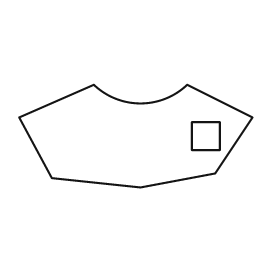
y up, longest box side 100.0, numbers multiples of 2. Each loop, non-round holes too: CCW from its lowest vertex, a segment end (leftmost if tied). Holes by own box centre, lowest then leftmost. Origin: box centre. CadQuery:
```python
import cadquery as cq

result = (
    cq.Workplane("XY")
    .moveTo(2.0, -22.0)
    .lineTo(34.0, -16.0)
    .lineTo(50.0, 8.0)
    .lineTo(22.0, 22.0)
    .threePointArc((2.0, 14.0), (-18.0, 22.0))
    .lineTo(-50.0, 8.0)
    .lineTo(-36.0, -18.0)
    .close()
    .moveTo(24.0, -6.0)
    .lineTo(36.0, -6.0)
    .lineTo(36.0, 6.0)
    .lineTo(24.0, 6.0)
    .close()
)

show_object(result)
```